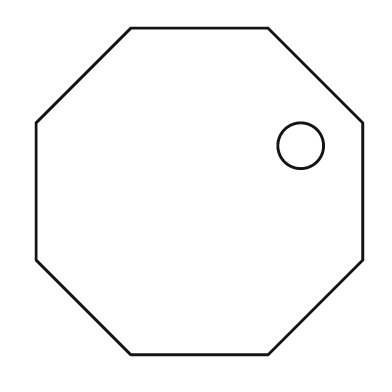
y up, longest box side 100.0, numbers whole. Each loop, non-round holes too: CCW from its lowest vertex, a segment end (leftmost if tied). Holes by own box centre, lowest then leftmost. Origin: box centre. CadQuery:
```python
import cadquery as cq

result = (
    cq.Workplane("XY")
    .moveTo(-21.0, -50.0)
    .lineTo(21.0, -50.0)
    .lineTo(50.0, -21.0)
    .lineTo(50.0, 21.0)
    .lineTo(21.0, 50.0)
    .lineTo(-21.0, 50.0)
    .lineTo(-50.0, 21.0)
    .lineTo(-50.0, -21.0)
    .close()
    .moveTo(31.0, 14.0)
    .circle(7.0)
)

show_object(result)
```